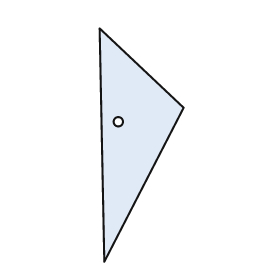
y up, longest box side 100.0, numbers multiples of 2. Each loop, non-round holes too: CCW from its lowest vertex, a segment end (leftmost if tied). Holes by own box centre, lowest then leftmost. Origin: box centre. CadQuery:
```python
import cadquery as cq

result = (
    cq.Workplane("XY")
    .moveTo(-16.0, -50.0)
    .lineTo(18.0, 16.0)
    .lineTo(-18.0, 50.0)
    .close()
    .moveTo(-10.0, 10.0)
    .circle(2.0)
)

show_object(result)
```